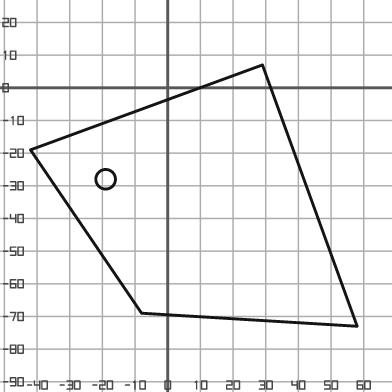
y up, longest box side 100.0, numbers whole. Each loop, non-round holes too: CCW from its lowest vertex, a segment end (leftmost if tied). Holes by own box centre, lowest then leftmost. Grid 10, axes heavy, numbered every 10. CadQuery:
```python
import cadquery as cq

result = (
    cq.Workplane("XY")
    .moveTo(58.0, -73.0)
    .lineTo(29.0, 7.0)
    .lineTo(-42.0, -19.0)
    .lineTo(-8.0, -69.0)
    .close()
    .moveTo(-19.0, -28.0)
    .circle(3.0)
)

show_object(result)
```